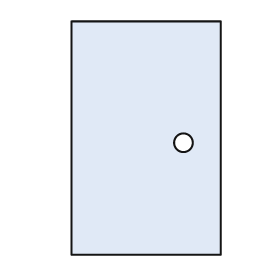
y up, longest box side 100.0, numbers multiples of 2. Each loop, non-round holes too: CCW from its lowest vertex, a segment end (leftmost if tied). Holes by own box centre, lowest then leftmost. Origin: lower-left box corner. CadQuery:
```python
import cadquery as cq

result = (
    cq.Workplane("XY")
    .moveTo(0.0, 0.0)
    .lineTo(64.0, 0.0)
    .lineTo(64.0, 100.0)
    .lineTo(0.0, 100.0)
    .close()
    .moveTo(48.0, 48.0)
    .circle(4.0)
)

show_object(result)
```